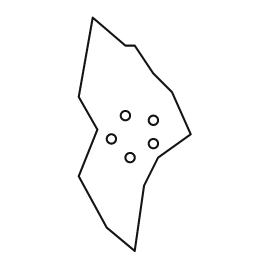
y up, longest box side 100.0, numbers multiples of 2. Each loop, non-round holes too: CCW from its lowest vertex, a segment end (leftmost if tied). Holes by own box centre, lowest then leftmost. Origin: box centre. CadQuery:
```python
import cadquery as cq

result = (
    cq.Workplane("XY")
    .moveTo(0.0, -50.0)
    .lineTo(4.0, -22.0)
    .lineTo(10.0, -10.0)
    .lineTo(24.0, 0.0)
    .lineTo(16.0, 18.0)
    .lineTo(8.0, 26.0)
    .lineTo(0.0, 38.0)
    .lineTo(-4.0, 38.0)
    .lineTo(-18.0, 50.0)
    .lineTo(-24.0, 16.0)
    .lineTo(-16.0, 2.0)
    .lineTo(-24.0, -18.0)
    .lineTo(-12.0, -40.0)
    .close()
    .moveTo(-2.0, -10.0)
    .circle(2.0)
    .moveTo(8.0, -4.0)
    .circle(2.0)
    .moveTo(-10.0, -2.0)
    .circle(2.0)
    .moveTo(8.0, 6.0)
    .circle(2.0)
    .moveTo(-4.0, 8.0)
    .circle(2.0)
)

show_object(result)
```